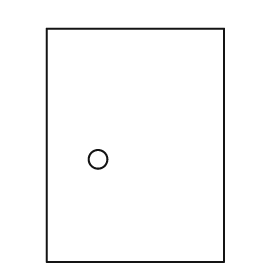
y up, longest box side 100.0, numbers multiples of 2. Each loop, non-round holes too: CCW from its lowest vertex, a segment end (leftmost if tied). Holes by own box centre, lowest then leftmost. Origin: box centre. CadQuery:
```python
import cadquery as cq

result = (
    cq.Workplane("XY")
    .moveTo(-38.0, -50.0)
    .lineTo(38.0, -50.0)
    .lineTo(38.0, 50.0)
    .lineTo(-38.0, 50.0)
    .close()
    .moveTo(-16.0, -6.0)
    .circle(4.0)
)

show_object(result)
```